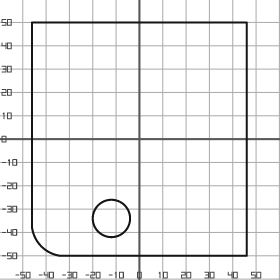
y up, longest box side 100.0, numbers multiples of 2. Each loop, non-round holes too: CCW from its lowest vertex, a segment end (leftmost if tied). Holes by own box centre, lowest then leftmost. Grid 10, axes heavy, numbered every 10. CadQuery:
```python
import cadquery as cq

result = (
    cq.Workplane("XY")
    .moveTo(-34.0, -50.0)
    .lineTo(46.0, -50.0)
    .lineTo(46.0, 50.0)
    .lineTo(-46.0, 50.0)
    .lineTo(-46.0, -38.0)
    .threePointArc((-42.0, -46.0), (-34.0, -50.0))
    .close()
    .moveTo(-12.0, -34.0)
    .circle(8.0)
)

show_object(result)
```